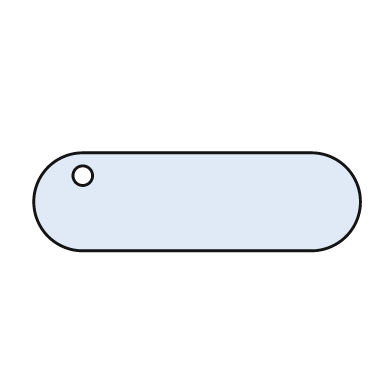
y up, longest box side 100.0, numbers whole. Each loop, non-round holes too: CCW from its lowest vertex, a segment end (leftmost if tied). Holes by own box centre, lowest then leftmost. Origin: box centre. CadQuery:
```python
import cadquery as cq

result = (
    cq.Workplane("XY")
    .moveTo(-35.0, -15.0)
    .lineTo(35.0, -15.0)
    .threePointArc((50.0, 0.0), (35.0, 15.0))
    .lineTo(-35.0, 15.0)
    .threePointArc((-50.0, 0.0), (-35.0, -15.0))
    .close()
    .moveTo(-35.0, 8.0)
    .circle(3.0)
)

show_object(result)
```